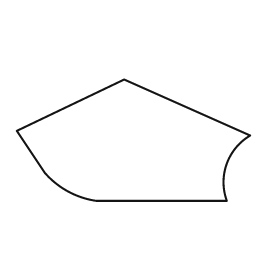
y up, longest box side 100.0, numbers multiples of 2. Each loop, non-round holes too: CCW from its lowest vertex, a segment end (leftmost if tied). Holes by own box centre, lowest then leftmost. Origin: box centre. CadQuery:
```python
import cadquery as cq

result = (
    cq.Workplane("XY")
    .moveTo(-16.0, -26.0)
    .lineTo(40.0, -26.0)
    .threePointArc((40.0, -10.0), (50.0, 2.0))
    .lineTo(-4.0, 26.0)
    .lineTo(-50.0, 4.0)
    .lineTo(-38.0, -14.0)
    .threePointArc((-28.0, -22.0), (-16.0, -26.0))
    .close()
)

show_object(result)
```